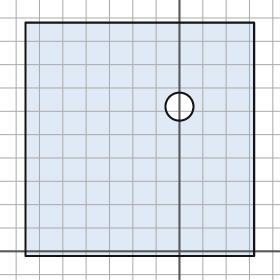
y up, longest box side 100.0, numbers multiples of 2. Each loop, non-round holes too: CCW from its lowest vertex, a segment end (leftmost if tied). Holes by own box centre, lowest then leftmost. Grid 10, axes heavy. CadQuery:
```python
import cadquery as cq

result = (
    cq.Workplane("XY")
    .moveTo(-66.0, -2.0)
    .lineTo(32.0, -2.0)
    .lineTo(32.0, 98.0)
    .lineTo(-66.0, 98.0)
    .close()
    .moveTo(0.0, 62.0)
    .circle(6.0)
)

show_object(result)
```